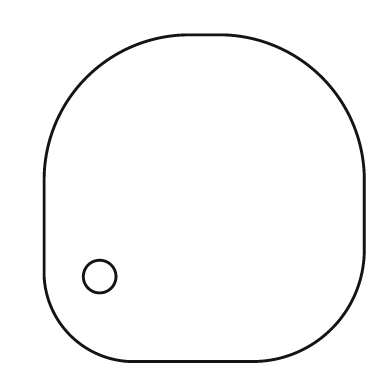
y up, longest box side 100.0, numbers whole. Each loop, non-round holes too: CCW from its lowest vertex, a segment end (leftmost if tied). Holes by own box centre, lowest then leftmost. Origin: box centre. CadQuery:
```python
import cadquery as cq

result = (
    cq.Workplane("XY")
    .moveTo(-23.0, -50.0)
    .lineTo(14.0, -50.0)
    .threePointArc((39.0, -40.0), (49.0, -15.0))
    .lineTo(49.0, 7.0)
    .threePointArc((36.0, 37.0), (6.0, 50.0))
    .lineTo(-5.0, 50.0)
    .threePointArc((-36.0, 37.0), (-49.0, 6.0))
    .lineTo(-49.0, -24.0)
    .threePointArc((-41.0, -42.0), (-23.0, -50.0))
    .close()
    .moveTo(-32.0, -24.0)
    .circle(5.0)
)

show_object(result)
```